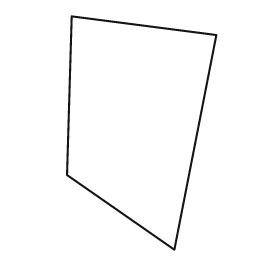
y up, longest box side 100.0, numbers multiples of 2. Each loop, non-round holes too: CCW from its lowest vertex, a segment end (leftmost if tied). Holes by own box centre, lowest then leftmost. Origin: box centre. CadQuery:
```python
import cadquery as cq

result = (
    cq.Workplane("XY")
    .moveTo(14.0, -50.0)
    .lineTo(32.0, 42.0)
    .lineTo(-30.0, 50.0)
    .lineTo(-32.0, -18.0)
    .close()
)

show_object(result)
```